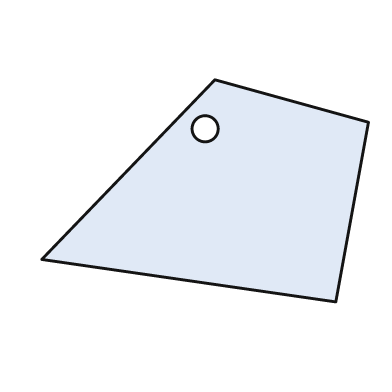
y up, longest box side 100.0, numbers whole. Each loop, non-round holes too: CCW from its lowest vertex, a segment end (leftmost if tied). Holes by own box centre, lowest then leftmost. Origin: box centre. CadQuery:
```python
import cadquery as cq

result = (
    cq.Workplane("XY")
    .moveTo(40.0, -34.0)
    .lineTo(50.0, 21.0)
    .lineTo(3.0, 34.0)
    .lineTo(-50.0, -21.0)
    .close()
    .moveTo(0.0, 19.0)
    .circle(4.0)
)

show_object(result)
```